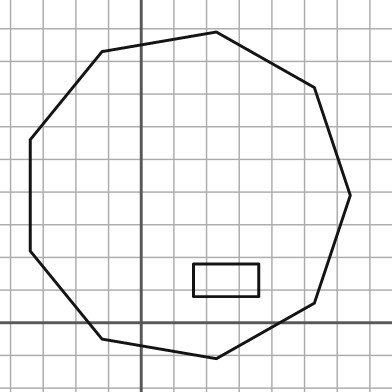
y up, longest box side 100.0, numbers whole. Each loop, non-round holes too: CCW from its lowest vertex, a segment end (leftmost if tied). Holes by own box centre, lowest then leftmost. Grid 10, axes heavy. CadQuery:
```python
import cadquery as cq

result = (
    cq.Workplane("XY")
    .moveTo(23.0, -11.0)
    .lineTo(53.0, 6.0)
    .lineTo(64.0, 39.0)
    .lineTo(53.0, 72.0)
    .lineTo(23.0, 89.0)
    .lineTo(-12.0, 83.0)
    .lineTo(-34.0, 56.0)
    .lineTo(-34.0, 22.0)
    .lineTo(-12.0, -5.0)
    .close()
    .moveTo(16.0, 8.0)
    .lineTo(36.0, 8.0)
    .lineTo(36.0, 18.0)
    .lineTo(16.0, 18.0)
    .close()
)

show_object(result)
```